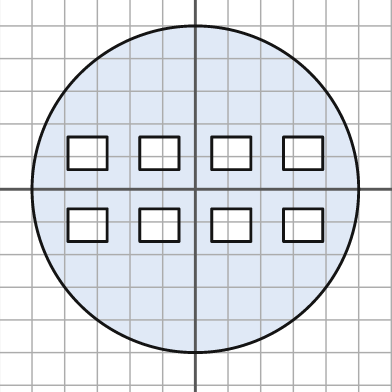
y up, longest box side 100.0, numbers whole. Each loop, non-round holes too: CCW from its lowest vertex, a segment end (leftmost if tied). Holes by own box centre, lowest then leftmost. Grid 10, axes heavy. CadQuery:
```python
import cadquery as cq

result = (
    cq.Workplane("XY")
    .moveTo(0.0, 0.0)
    .circle(50.0)
    .moveTo(-39.0, -16.0)
    .lineTo(-27.0, -16.0)
    .lineTo(-27.0, -6.0)
    .lineTo(-39.0, -6.0)
    .close()
    .moveTo(-17.0, -16.0)
    .lineTo(-5.0, -16.0)
    .lineTo(-5.0, -6.0)
    .lineTo(-17.0, -6.0)
    .close()
    .moveTo(5.0, -16.0)
    .lineTo(17.0, -16.0)
    .lineTo(17.0, -6.0)
    .lineTo(5.0, -6.0)
    .close()
    .moveTo(27.0, -16.0)
    .lineTo(39.0, -16.0)
    .lineTo(39.0, -6.0)
    .lineTo(27.0, -6.0)
    .close()
    .moveTo(-39.0, 6.0)
    .lineTo(-27.0, 6.0)
    .lineTo(-27.0, 16.0)
    .lineTo(-39.0, 16.0)
    .close()
    .moveTo(-17.0, 6.0)
    .lineTo(-5.0, 6.0)
    .lineTo(-5.0, 16.0)
    .lineTo(-17.0, 16.0)
    .close()
    .moveTo(5.0, 6.0)
    .lineTo(17.0, 6.0)
    .lineTo(17.0, 16.0)
    .lineTo(5.0, 16.0)
    .close()
    .moveTo(27.0, 6.0)
    .lineTo(39.0, 6.0)
    .lineTo(39.0, 16.0)
    .lineTo(27.0, 16.0)
    .close()
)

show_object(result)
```